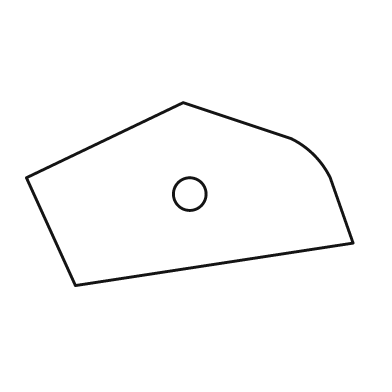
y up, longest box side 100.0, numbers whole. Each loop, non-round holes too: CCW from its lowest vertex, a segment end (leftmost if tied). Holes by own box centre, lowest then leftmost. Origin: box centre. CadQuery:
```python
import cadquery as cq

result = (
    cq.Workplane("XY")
    .moveTo(-35.0, -28.0)
    .lineTo(50.0, -15.0)
    .lineTo(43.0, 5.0)
    .threePointArc((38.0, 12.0), (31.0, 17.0))
    .lineTo(-2.0, 28.0)
    .lineTo(-50.0, 5.0)
    .close()
    .moveTo(0.0, 0.0)
    .circle(5.0)
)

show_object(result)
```